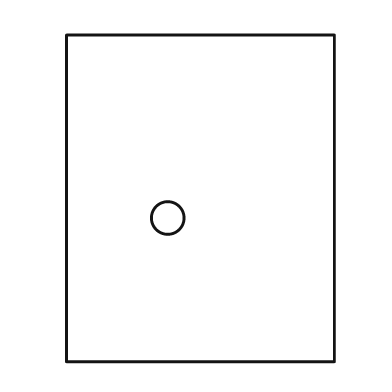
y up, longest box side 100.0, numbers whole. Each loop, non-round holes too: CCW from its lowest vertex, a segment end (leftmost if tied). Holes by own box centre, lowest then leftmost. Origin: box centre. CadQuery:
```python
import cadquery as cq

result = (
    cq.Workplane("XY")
    .moveTo(-41.0, -50.0)
    .lineTo(41.0, -50.0)
    .lineTo(41.0, 50.0)
    .lineTo(-41.0, 50.0)
    .close()
    .moveTo(-10.0, -6.0)
    .circle(5.0)
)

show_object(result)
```